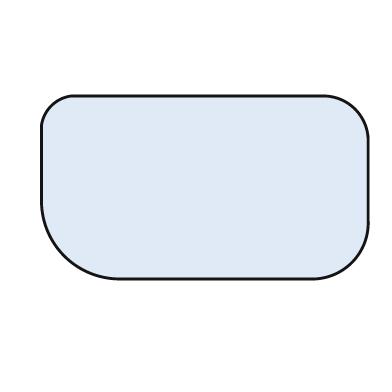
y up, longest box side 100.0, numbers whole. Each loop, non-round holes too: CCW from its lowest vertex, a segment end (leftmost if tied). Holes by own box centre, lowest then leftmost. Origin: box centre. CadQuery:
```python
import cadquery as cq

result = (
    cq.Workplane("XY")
    .moveTo(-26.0, -28.0)
    .lineTo(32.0, -28.0)
    .threePointArc((45.0, -23.0), (50.0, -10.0))
    .lineTo(50.0, 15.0)
    .threePointArc((46.0, 24.0), (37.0, 28.0))
    .lineTo(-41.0, 28.0)
    .threePointArc((-47.0, 25.0), (-50.0, 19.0))
    .lineTo(-50.0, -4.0)
    .threePointArc((-43.0, -21.0), (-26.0, -28.0))
    .close()
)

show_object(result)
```